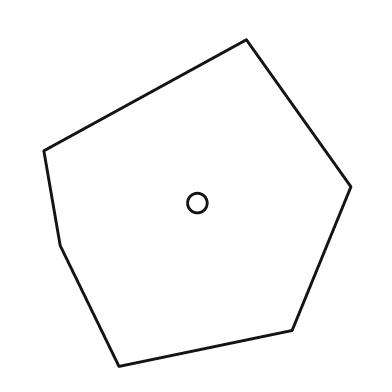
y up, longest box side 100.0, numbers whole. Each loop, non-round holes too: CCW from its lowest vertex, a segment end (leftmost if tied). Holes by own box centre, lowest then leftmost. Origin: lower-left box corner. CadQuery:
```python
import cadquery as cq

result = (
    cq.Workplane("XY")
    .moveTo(23.0, 0.0)
    .lineTo(76.0, 11.0)
    .lineTo(94.0, 55.0)
    .lineTo(62.0, 100.0)
    .lineTo(0.0, 66.0)
    .lineTo(5.0, 37.0)
    .close()
    .moveTo(47.0, 50.0)
    .circle(3.0)
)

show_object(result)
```